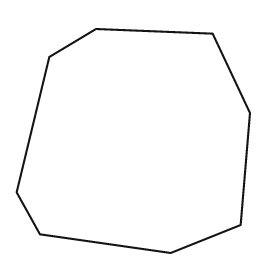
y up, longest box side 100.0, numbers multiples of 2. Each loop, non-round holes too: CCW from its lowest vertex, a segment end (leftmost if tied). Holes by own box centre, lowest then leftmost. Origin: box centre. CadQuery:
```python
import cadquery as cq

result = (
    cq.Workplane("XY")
    .moveTo(16.0, -48.0)
    .lineTo(46.0, -36.0)
    .lineTo(50.0, 12.0)
    .lineTo(34.0, 46.0)
    .lineTo(-16.0, 48.0)
    .lineTo(-36.0, 36.0)
    .lineTo(-50.0, -22.0)
    .lineTo(-40.0, -40.0)
    .close()
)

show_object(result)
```